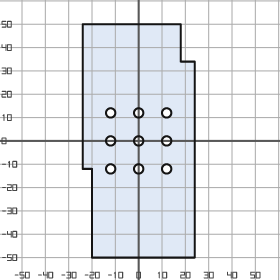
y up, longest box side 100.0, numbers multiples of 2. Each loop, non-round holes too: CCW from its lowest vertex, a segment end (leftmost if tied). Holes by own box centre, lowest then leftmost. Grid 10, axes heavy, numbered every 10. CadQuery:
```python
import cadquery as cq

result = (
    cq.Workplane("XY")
    .moveTo(-20.0, -50.0)
    .lineTo(24.0, -50.0)
    .lineTo(24.0, 34.0)
    .lineTo(18.0, 34.0)
    .lineTo(18.0, 50.0)
    .lineTo(-24.0, 50.0)
    .lineTo(-24.0, -12.0)
    .lineTo(-20.0, -12.0)
    .close()
    .moveTo(-12.0, -12.0)
    .circle(2.0)
    .moveTo(0.0, -12.0)
    .circle(2.0)
    .moveTo(12.0, -12.0)
    .circle(2.0)
    .moveTo(-12.0, 0.0)
    .circle(2.0)
    .moveTo(0.0, 0.0)
    .circle(2.0)
    .moveTo(12.0, 0.0)
    .circle(2.0)
    .moveTo(-12.0, 12.0)
    .circle(2.0)
    .moveTo(0.0, 12.0)
    .circle(2.0)
    .moveTo(12.0, 12.0)
    .circle(2.0)
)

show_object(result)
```